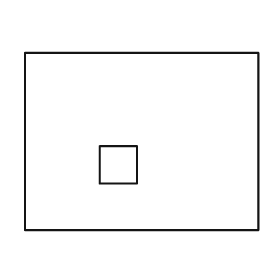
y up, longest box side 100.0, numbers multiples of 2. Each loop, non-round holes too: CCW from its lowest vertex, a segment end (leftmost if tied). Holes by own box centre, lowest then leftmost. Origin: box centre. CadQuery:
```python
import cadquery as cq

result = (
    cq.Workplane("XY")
    .moveTo(-50.0, -38.0)
    .lineTo(50.0, -38.0)
    .lineTo(50.0, 38.0)
    .lineTo(-50.0, 38.0)
    .close()
    .moveTo(-18.0, -18.0)
    .lineTo(-2.0, -18.0)
    .lineTo(-2.0, -2.0)
    .lineTo(-18.0, -2.0)
    .close()
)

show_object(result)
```